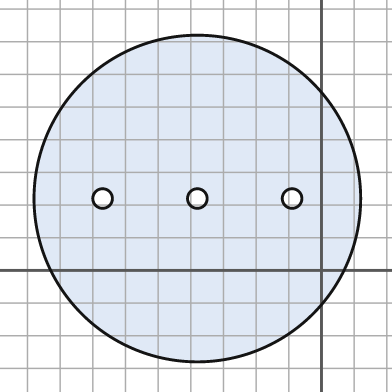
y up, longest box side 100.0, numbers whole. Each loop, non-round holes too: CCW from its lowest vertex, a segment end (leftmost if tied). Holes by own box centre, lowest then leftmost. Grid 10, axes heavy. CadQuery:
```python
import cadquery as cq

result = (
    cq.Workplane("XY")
    .moveTo(-38.0, 22.0)
    .circle(50.0)
    .moveTo(-67.0, 22.0)
    .circle(3.0)
    .moveTo(-38.0, 22.0)
    .circle(3.0)
    .moveTo(-9.0, 22.0)
    .circle(3.0)
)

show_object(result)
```